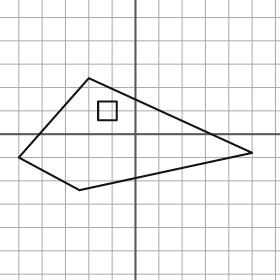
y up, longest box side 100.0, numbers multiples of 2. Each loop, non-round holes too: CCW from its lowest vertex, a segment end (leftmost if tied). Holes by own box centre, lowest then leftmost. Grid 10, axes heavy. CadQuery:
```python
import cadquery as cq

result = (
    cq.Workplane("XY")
    .moveTo(-24.0, -24.0)
    .lineTo(50.0, -8.0)
    .lineTo(-20.0, 24.0)
    .lineTo(-50.0, -10.0)
    .close()
    .moveTo(-16.0, 6.0)
    .lineTo(-8.0, 6.0)
    .lineTo(-8.0, 14.0)
    .lineTo(-16.0, 14.0)
    .close()
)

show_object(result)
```